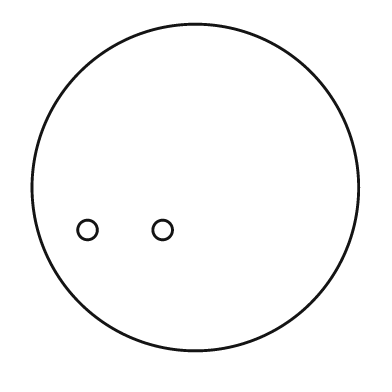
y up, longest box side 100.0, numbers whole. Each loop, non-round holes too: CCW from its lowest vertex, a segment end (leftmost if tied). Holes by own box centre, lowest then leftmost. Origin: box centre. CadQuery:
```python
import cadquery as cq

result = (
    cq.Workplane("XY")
    .moveTo(0.0, 0.0)
    .circle(50.0)
    .moveTo(-33.0, -13.0)
    .circle(3.0)
    .moveTo(-10.0, -13.0)
    .circle(3.0)
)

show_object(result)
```